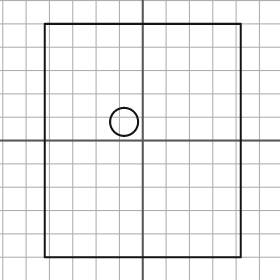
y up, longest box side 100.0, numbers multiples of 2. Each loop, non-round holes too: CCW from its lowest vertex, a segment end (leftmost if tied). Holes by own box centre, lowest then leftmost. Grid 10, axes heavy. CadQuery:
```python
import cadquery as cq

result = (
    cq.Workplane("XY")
    .moveTo(-42.0, -50.0)
    .lineTo(42.0, -50.0)
    .lineTo(42.0, 50.0)
    .lineTo(-42.0, 50.0)
    .close()
    .moveTo(-8.0, 8.0)
    .circle(6.0)
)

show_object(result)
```